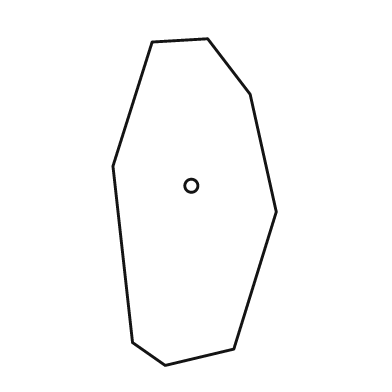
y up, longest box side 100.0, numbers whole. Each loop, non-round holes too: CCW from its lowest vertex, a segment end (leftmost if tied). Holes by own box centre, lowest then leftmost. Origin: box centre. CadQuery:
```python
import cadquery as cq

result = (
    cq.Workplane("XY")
    .moveTo(-9.0, -50.0)
    .lineTo(12.0, -45.0)
    .lineTo(25.0, -3.0)
    .lineTo(17.0, 33.0)
    .lineTo(4.0, 50.0)
    .lineTo(-13.0, 49.0)
    .lineTo(-25.0, 11.0)
    .lineTo(-19.0, -43.0)
    .close()
    .moveTo(-1.0, 5.0)
    .circle(2.0)
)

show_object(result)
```